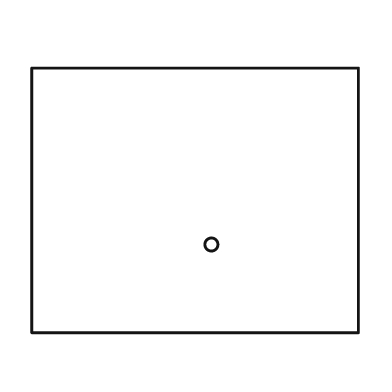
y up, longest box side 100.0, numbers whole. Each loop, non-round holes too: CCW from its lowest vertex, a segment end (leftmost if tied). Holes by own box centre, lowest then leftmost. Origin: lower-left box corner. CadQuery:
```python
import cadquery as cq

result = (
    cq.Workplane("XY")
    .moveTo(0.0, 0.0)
    .lineTo(100.0, 0.0)
    .lineTo(100.0, 81.0)
    .lineTo(0.0, 81.0)
    .close()
    .moveTo(55.0, 27.0)
    .circle(2.0)
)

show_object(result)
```